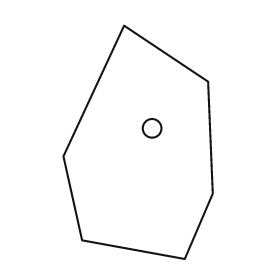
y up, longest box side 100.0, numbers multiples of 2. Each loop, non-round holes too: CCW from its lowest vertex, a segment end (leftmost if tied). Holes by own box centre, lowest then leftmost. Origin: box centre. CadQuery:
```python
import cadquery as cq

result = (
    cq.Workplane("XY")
    .moveTo(20.0, -50.0)
    .lineTo(32.0, -22.0)
    .lineTo(30.0, 26.0)
    .lineTo(-6.0, 50.0)
    .lineTo(-32.0, -6.0)
    .lineTo(-24.0, -42.0)
    .close()
    .moveTo(6.0, 6.0)
    .circle(4.0)
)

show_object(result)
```